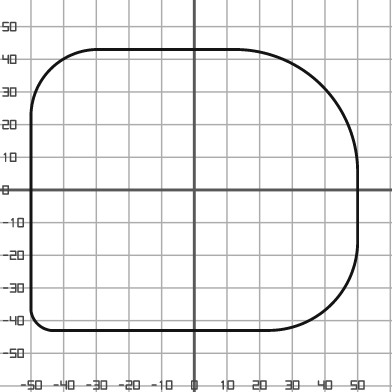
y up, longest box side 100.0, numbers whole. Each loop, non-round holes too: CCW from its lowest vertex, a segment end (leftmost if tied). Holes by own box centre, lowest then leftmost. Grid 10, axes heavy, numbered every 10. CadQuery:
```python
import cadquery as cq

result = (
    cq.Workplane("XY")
    .moveTo(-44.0, -43.0)
    .lineTo(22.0, -43.0)
    .threePointArc((42.0, -35.0), (50.0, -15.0))
    .lineTo(50.0, 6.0)
    .threePointArc((39.0, 32.0), (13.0, 43.0))
    .lineTo(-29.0, 43.0)
    .threePointArc((-44.0, 37.0), (-50.0, 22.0))
    .lineTo(-50.0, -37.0)
    .threePointArc((-48.0, -41.0), (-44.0, -43.0))
    .close()
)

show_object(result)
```